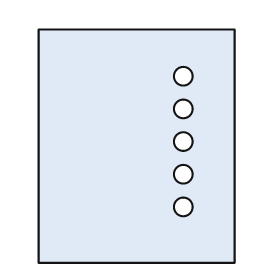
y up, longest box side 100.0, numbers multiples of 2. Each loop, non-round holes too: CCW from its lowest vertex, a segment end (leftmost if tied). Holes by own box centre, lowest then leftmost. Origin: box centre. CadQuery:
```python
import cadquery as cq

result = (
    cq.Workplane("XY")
    .moveTo(-42.0, -50.0)
    .lineTo(42.0, -50.0)
    .lineTo(42.0, 50.0)
    .lineTo(-42.0, 50.0)
    .close()
    .moveTo(20.0, -26.0)
    .circle(4.0)
    .moveTo(20.0, -12.0)
    .circle(4.0)
    .moveTo(20.0, 2.0)
    .circle(4.0)
    .moveTo(20.0, 16.0)
    .circle(4.0)
    .moveTo(20.0, 30.0)
    .circle(4.0)
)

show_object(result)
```